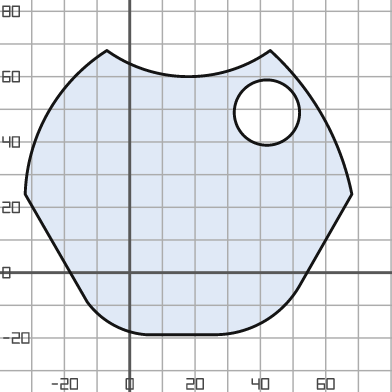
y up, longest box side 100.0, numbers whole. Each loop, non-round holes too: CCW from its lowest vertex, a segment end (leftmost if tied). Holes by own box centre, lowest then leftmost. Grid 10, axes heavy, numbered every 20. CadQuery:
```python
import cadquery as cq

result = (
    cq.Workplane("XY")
    .moveTo(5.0, -19.0)
    .lineTo(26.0, -19.0)
    .threePointArc((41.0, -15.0), (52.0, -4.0))
    .lineTo(68.0, 24.0)
    .threePointArc((59.0, 48.0), (43.0, 68.0))
    .threePointArc((18.0, 60.0), (-7.0, 68.0))
    .threePointArc((-25.0, 49.0), (-32.0, 24.0))
    .lineTo(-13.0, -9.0)
    .threePointArc((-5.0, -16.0), (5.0, -19.0))
    .close()
    .moveTo(42.0, 49.0)
    .circle(10.0)
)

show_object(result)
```